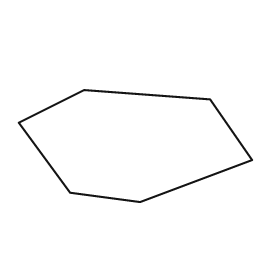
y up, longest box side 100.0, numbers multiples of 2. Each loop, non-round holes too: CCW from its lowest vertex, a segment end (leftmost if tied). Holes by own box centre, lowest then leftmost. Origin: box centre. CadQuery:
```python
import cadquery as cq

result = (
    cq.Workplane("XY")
    .moveTo(2.0, -24.0)
    .lineTo(50.0, -6.0)
    .lineTo(32.0, 20.0)
    .lineTo(-22.0, 24.0)
    .lineTo(-50.0, 10.0)
    .lineTo(-28.0, -20.0)
    .close()
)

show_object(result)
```